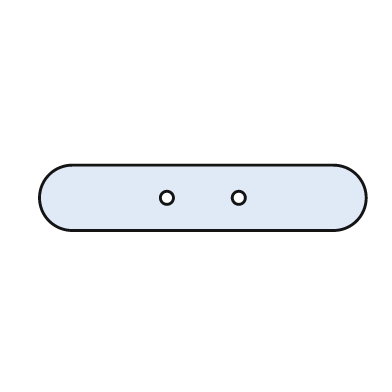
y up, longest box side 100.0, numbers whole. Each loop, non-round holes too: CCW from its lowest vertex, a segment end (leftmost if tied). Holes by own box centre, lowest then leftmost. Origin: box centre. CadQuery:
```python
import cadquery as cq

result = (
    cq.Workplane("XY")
    .moveTo(-40.0, -10.0)
    .lineTo(40.0, -10.0)
    .threePointArc((50.0, 0.0), (40.0, 10.0))
    .lineTo(-40.0, 10.0)
    .threePointArc((-50.0, 0.0), (-40.0, -10.0))
    .close()
    .moveTo(-11.0, 0.0)
    .circle(2.0)
    .moveTo(11.0, 0.0)
    .circle(2.0)
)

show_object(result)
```